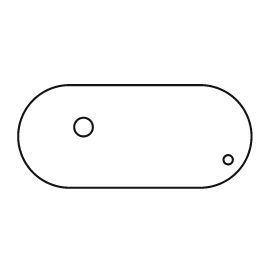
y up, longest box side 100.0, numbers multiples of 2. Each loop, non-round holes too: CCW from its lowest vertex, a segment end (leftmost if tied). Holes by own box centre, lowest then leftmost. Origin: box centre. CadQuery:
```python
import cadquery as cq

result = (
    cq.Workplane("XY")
    .moveTo(-28.0, -22.0)
    .lineTo(28.0, -22.0)
    .threePointArc((50.0, 0.0), (28.0, 22.0))
    .lineTo(-28.0, 22.0)
    .threePointArc((-50.0, 0.0), (-28.0, -22.0))
    .close()
    .moveTo(40.0, -10.0)
    .circle(2.0)
    .moveTo(-22.0, 4.0)
    .circle(4.0)
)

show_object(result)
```